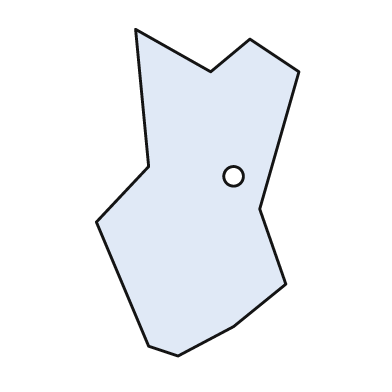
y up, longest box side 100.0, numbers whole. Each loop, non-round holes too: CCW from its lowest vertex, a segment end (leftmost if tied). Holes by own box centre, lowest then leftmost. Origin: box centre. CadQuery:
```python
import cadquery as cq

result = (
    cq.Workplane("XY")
    .moveTo(-6.0, -50.0)
    .lineTo(11.0, -41.0)
    .lineTo(27.0, -28.0)
    .lineTo(19.0, -5.0)
    .lineTo(31.0, 37.0)
    .lineTo(16.0, 47.0)
    .lineTo(4.0, 37.0)
    .lineTo(-19.0, 50.0)
    .lineTo(-15.0, 8.0)
    .lineTo(-31.0, -9.0)
    .lineTo(-15.0, -47.0)
    .close()
    .moveTo(11.0, 5.0)
    .circle(3.0)
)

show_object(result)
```